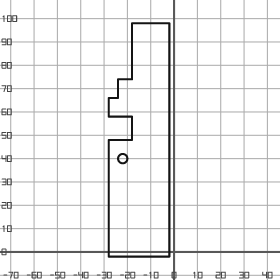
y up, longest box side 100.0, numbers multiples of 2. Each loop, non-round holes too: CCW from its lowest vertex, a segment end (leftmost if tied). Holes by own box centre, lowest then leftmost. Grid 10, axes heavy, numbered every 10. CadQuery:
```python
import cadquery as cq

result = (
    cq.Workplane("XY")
    .moveTo(-28.0, -2.0)
    .lineTo(-2.0, -2.0)
    .lineTo(-2.0, 98.0)
    .lineTo(-18.0, 98.0)
    .lineTo(-18.0, 74.0)
    .lineTo(-24.0, 74.0)
    .lineTo(-24.0, 66.0)
    .lineTo(-28.0, 66.0)
    .lineTo(-28.0, 58.0)
    .lineTo(-18.0, 58.0)
    .lineTo(-18.0, 48.0)
    .lineTo(-28.0, 48.0)
    .close()
    .moveTo(-22.0, 40.0)
    .circle(2.0)
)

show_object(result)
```